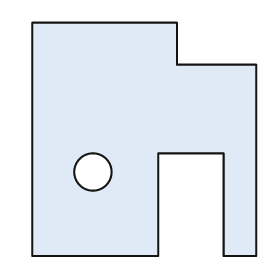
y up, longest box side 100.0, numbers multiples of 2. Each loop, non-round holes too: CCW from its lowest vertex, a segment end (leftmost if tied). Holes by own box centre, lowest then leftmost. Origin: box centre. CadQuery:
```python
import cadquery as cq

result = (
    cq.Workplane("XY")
    .moveTo(-48.0, -50.0)
    .lineTo(6.0, -50.0)
    .lineTo(6.0, -6.0)
    .lineTo(34.0, -6.0)
    .lineTo(34.0, -50.0)
    .lineTo(48.0, -50.0)
    .lineTo(48.0, 32.0)
    .lineTo(14.0, 32.0)
    .lineTo(14.0, 50.0)
    .lineTo(-48.0, 50.0)
    .close()
    .moveTo(-22.0, -14.0)
    .circle(8.0)
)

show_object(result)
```